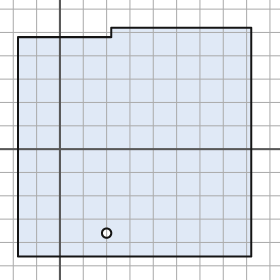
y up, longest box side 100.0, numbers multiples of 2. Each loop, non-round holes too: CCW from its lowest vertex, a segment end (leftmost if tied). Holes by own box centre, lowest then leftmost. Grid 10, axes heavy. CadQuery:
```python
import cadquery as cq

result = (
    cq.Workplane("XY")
    .moveTo(-18.0, -46.0)
    .lineTo(82.0, -46.0)
    .lineTo(82.0, 52.0)
    .lineTo(22.0, 52.0)
    .lineTo(22.0, 48.0)
    .lineTo(-18.0, 48.0)
    .close()
    .moveTo(20.0, -36.0)
    .circle(2.0)
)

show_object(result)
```